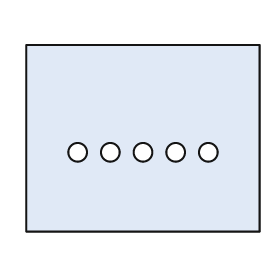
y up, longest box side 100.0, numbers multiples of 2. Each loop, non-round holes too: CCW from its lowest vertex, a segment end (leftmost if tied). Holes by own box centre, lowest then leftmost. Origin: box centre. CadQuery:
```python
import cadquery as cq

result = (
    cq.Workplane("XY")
    .moveTo(-50.0, -40.0)
    .lineTo(50.0, -40.0)
    .lineTo(50.0, 40.0)
    .lineTo(-50.0, 40.0)
    .close()
    .moveTo(-28.0, -6.0)
    .circle(4.0)
    .moveTo(-14.0, -6.0)
    .circle(4.0)
    .moveTo(0.0, -6.0)
    .circle(4.0)
    .moveTo(14.0, -6.0)
    .circle(4.0)
    .moveTo(28.0, -6.0)
    .circle(4.0)
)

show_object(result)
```